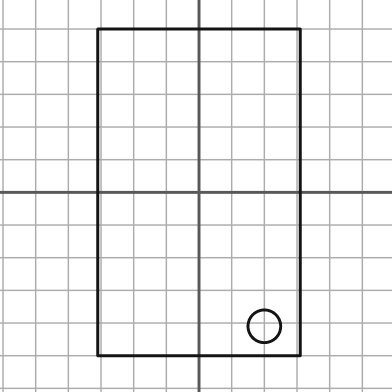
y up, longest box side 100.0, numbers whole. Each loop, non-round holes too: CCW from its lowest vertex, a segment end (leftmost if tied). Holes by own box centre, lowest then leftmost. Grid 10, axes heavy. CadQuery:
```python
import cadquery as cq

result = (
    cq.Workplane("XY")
    .moveTo(-31.0, -50.0)
    .lineTo(31.0, -50.0)
    .lineTo(31.0, 50.0)
    .lineTo(-31.0, 50.0)
    .close()
    .moveTo(20.0, -41.0)
    .circle(5.0)
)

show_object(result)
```